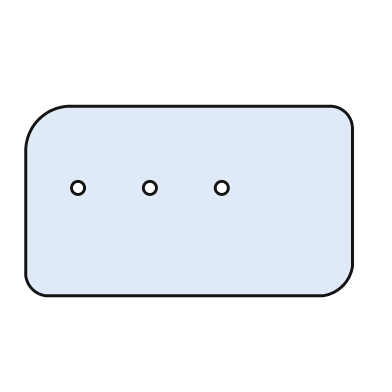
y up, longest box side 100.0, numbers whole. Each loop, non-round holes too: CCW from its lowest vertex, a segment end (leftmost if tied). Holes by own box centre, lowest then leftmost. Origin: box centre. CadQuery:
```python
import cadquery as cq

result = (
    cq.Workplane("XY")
    .moveTo(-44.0, -29.0)
    .lineTo(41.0, -29.0)
    .threePointArc((47.0, -26.0), (50.0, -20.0))
    .lineTo(50.0, 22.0)
    .threePointArc((48.0, 27.0), (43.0, 29.0))
    .lineTo(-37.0, 29.0)
    .threePointArc((-46.0, 25.0), (-50.0, 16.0))
    .lineTo(-50.0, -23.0)
    .threePointArc((-48.0, -27.0), (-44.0, -29.0))
    .close()
    .moveTo(-34.0, 4.0)
    .circle(2.0)
    .moveTo(-12.0, 4.0)
    .circle(2.0)
    .moveTo(10.0, 4.0)
    .circle(2.0)
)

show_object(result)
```